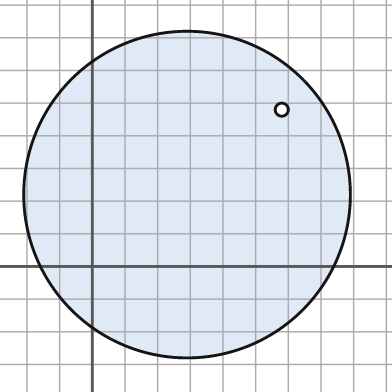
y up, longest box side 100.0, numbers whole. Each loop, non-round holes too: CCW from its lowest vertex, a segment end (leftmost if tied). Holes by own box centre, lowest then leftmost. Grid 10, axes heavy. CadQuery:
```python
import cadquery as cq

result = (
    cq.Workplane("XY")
    .moveTo(29.0, 22.0)
    .circle(50.0)
    .moveTo(58.0, 48.0)
    .circle(2.0)
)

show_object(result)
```